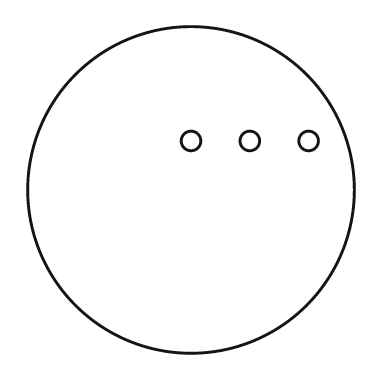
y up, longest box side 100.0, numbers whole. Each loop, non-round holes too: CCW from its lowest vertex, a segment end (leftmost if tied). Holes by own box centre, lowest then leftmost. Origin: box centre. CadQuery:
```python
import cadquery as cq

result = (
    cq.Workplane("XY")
    .moveTo(0.0, 0.0)
    .circle(50.0)
    .moveTo(0.0, 15.0)
    .circle(3.0)
    .moveTo(18.0, 15.0)
    .circle(3.0)
    .moveTo(36.0, 15.0)
    .circle(3.0)
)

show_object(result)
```